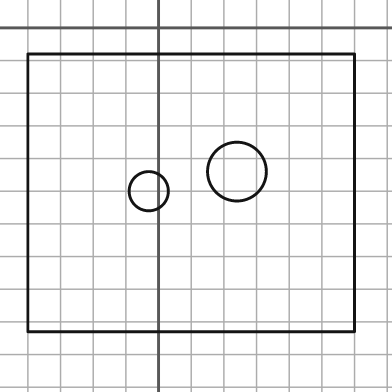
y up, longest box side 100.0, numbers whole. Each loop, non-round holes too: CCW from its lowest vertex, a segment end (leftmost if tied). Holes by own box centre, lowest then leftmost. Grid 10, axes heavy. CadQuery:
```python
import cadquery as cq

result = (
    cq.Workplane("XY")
    .moveTo(-40.0, -93.0)
    .lineTo(60.0, -93.0)
    .lineTo(60.0, -8.0)
    .lineTo(-40.0, -8.0)
    .close()
    .moveTo(-3.0, -50.0)
    .circle(6.0)
    .moveTo(24.0, -44.0)
    .circle(9.0)
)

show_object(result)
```